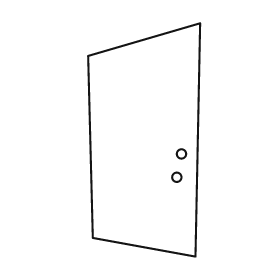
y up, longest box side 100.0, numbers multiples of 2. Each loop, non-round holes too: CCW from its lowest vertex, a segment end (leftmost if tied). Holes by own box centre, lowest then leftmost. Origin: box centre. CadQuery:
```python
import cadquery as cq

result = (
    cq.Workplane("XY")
    .moveTo(22.0, -50.0)
    .lineTo(24.0, 50.0)
    .lineTo(-24.0, 36.0)
    .lineTo(-22.0, -42.0)
    .close()
    .moveTo(14.0, -16.0)
    .circle(2.0)
    .moveTo(16.0, -6.0)
    .circle(2.0)
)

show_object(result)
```